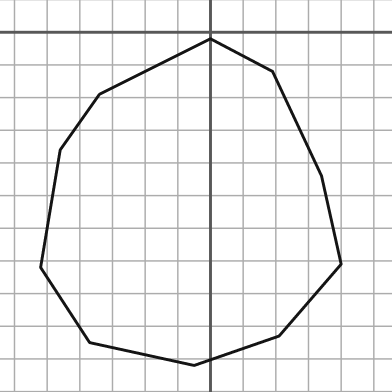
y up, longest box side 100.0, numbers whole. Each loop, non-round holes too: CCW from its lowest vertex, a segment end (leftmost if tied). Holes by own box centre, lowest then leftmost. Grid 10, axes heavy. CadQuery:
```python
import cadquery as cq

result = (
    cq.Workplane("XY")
    .moveTo(-5.0, -102.0)
    .lineTo(21.0, -93.0)
    .lineTo(40.0, -71.0)
    .lineTo(34.0, -44.0)
    .lineTo(19.0, -12.0)
    .lineTo(0.0, -2.0)
    .lineTo(-34.0, -19.0)
    .lineTo(-46.0, -36.0)
    .lineTo(-52.0, -72.0)
    .lineTo(-37.0, -95.0)
    .close()
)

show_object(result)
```